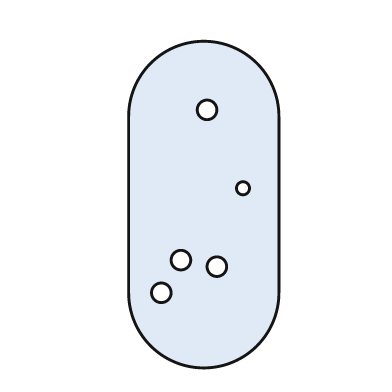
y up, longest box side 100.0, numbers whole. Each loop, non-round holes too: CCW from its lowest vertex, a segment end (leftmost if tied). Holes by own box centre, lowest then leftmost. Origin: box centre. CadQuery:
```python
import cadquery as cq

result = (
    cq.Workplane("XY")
    .moveTo(-23.0, -27.0)
    .threePointArc((0.0, -50.0), (23.0, -27.0))
    .lineTo(23.0, 27.0)
    .threePointArc((0.0, 50.0), (-23.0, 27.0))
    .close()
    .moveTo(-13.0, -27.0)
    .circle(3.0)
    .moveTo(4.0, -19.0)
    .circle(3.0)
    .moveTo(-7.0, -17.0)
    .circle(3.0)
    .moveTo(12.0, 5.0)
    .circle(2.0)
    .moveTo(1.0, 29.0)
    .circle(3.0)
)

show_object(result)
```